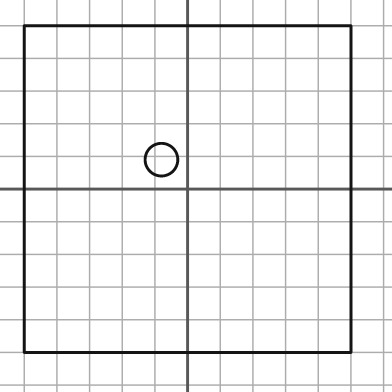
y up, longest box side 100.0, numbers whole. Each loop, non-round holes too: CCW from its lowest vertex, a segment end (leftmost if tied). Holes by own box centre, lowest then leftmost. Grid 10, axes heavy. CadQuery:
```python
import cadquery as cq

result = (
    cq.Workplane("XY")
    .moveTo(-50.0, -50.0)
    .lineTo(50.0, -50.0)
    .lineTo(50.0, 50.0)
    .lineTo(-50.0, 50.0)
    .close()
    .moveTo(-8.0, 9.0)
    .circle(5.0)
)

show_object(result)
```